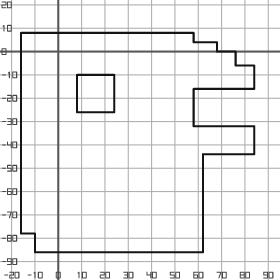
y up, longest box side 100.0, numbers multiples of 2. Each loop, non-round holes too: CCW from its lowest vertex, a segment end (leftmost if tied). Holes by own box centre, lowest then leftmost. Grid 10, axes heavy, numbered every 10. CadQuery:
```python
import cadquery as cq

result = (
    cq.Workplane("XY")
    .moveTo(-10.0, -86.0)
    .lineTo(62.0, -86.0)
    .lineTo(62.0, -44.0)
    .lineTo(84.0, -44.0)
    .lineTo(84.0, -32.0)
    .lineTo(58.0, -32.0)
    .lineTo(58.0, -16.0)
    .lineTo(84.0, -16.0)
    .lineTo(84.0, -6.0)
    .lineTo(76.0, -6.0)
    .lineTo(76.0, 0.0)
    .lineTo(68.0, 0.0)
    .lineTo(68.0, 4.0)
    .lineTo(58.0, 4.0)
    .lineTo(58.0, 8.0)
    .lineTo(-16.0, 8.0)
    .lineTo(-16.0, -78.0)
    .lineTo(-10.0, -78.0)
    .close()
    .moveTo(8.0, -26.0)
    .lineTo(24.0, -26.0)
    .lineTo(24.0, -10.0)
    .lineTo(8.0, -10.0)
    .close()
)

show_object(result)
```